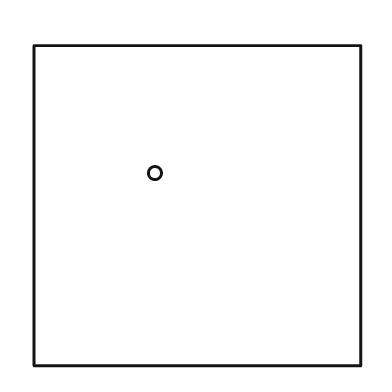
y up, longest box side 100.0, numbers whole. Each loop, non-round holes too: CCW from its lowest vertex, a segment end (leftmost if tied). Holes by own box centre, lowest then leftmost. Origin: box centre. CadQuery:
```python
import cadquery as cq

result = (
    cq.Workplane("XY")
    .moveTo(-50.0, -49.0)
    .lineTo(50.0, -49.0)
    .lineTo(50.0, 49.0)
    .lineTo(-50.0, 49.0)
    .close()
    .moveTo(-13.0, 10.0)
    .circle(2.0)
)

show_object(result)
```